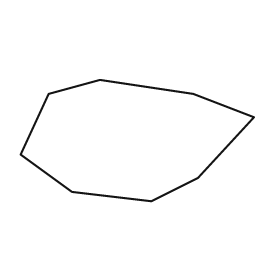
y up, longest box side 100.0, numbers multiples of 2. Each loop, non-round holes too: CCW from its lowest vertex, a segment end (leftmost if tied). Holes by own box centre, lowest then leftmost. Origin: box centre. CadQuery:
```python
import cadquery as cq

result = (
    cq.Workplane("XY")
    .moveTo(6.0, -26.0)
    .lineTo(26.0, -16.0)
    .lineTo(50.0, 10.0)
    .lineTo(24.0, 20.0)
    .lineTo(-16.0, 26.0)
    .lineTo(-38.0, 20.0)
    .lineTo(-50.0, -6.0)
    .lineTo(-28.0, -22.0)
    .close()
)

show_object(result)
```